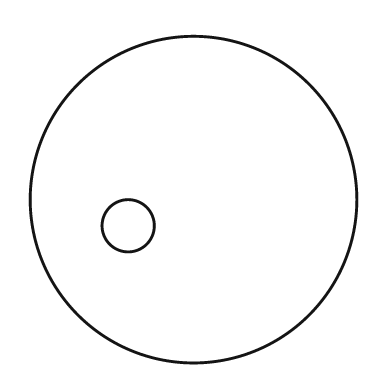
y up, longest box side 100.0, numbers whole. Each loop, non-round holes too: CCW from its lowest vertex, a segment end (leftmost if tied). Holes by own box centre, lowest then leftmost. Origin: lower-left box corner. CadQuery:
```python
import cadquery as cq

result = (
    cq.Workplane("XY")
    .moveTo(50.0, 50.0)
    .circle(50.0)
    .moveTo(30.0, 42.0)
    .circle(8.0)
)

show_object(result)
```